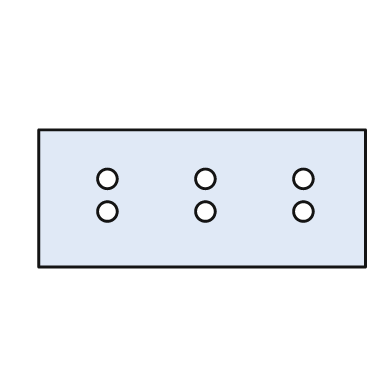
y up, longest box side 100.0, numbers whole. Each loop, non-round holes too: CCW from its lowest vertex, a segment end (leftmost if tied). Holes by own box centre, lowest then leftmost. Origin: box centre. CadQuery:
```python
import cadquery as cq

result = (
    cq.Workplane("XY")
    .moveTo(-50.0, -21.0)
    .lineTo(50.0, -21.0)
    .lineTo(50.0, 21.0)
    .lineTo(-50.0, 21.0)
    .close()
    .moveTo(-29.0, -4.0)
    .circle(3.0)
    .moveTo(1.0, -4.0)
    .circle(3.0)
    .moveTo(31.0, -4.0)
    .circle(3.0)
    .moveTo(-29.0, 6.0)
    .circle(3.0)
    .moveTo(1.0, 6.0)
    .circle(3.0)
    .moveTo(31.0, 6.0)
    .circle(3.0)
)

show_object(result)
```